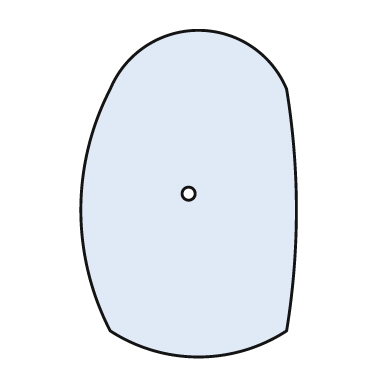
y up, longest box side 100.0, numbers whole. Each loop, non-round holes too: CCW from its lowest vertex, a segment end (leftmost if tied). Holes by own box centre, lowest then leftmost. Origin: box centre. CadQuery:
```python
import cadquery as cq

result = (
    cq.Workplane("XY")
    .moveTo(-24.0, -42.0)
    .threePointArc((3.0, -50.0), (30.0, -42.0))
    .threePointArc((33.0, -5.0), (30.0, 32.0))
    .threePointArc((3.0, 50.0), (-24.0, 32.0))
    .threePointArc((-33.0, -5.0), (-24.0, -42.0))
    .close()
    .moveTo(0.0, 0.0)
    .circle(2.0)
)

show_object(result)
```